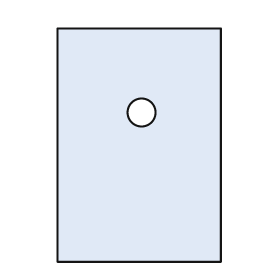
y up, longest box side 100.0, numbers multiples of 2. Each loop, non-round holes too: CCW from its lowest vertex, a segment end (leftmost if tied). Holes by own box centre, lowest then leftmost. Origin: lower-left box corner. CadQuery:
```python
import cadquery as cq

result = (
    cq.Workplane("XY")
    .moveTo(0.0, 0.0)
    .lineTo(70.0, 0.0)
    .lineTo(70.0, 100.0)
    .lineTo(0.0, 100.0)
    .close()
    .moveTo(36.0, 64.0)
    .circle(6.0)
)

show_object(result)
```